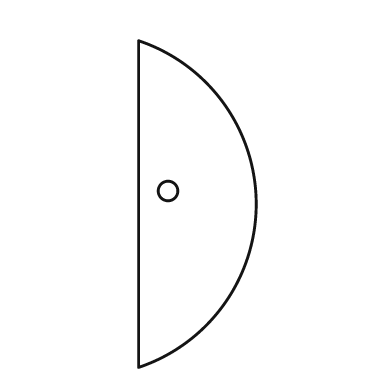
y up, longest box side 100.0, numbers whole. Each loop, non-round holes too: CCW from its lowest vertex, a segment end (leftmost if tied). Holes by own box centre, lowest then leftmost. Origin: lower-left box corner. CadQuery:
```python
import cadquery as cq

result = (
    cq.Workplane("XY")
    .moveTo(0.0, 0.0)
    .threePointArc((36.0, 50.0), (0.0, 100.0))
    .close()
    .moveTo(9.0, 54.0)
    .circle(3.0)
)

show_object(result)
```